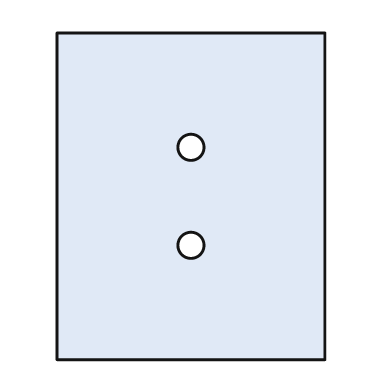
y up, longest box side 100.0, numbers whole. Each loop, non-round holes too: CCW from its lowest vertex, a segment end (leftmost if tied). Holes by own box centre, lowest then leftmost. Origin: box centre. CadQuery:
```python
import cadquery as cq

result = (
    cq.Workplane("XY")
    .moveTo(-41.0, -50.0)
    .lineTo(41.0, -50.0)
    .lineTo(41.0, 50.0)
    .lineTo(-41.0, 50.0)
    .close()
    .moveTo(0.0, -15.0)
    .circle(4.0)
    .moveTo(0.0, 15.0)
    .circle(4.0)
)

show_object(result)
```